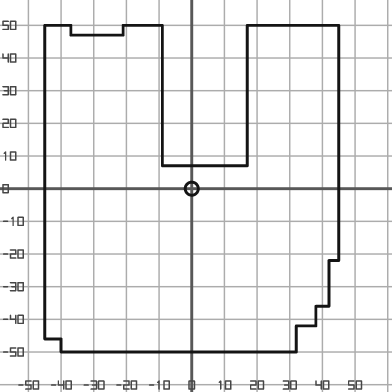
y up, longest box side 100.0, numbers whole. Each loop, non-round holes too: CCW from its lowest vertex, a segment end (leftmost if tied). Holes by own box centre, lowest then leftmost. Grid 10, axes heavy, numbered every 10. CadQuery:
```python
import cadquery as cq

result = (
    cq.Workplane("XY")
    .moveTo(-40.0, -50.0)
    .lineTo(32.0, -50.0)
    .lineTo(32.0, -42.0)
    .lineTo(38.0, -42.0)
    .lineTo(38.0, -36.0)
    .lineTo(42.0, -36.0)
    .lineTo(42.0, -22.0)
    .lineTo(45.0, -22.0)
    .lineTo(45.0, 50.0)
    .lineTo(17.0, 50.0)
    .lineTo(17.0, 7.0)
    .lineTo(-9.0, 7.0)
    .lineTo(-9.0, 50.0)
    .lineTo(-21.0, 50.0)
    .lineTo(-21.0, 47.0)
    .lineTo(-37.0, 47.0)
    .lineTo(-37.0, 50.0)
    .lineTo(-45.0, 50.0)
    .lineTo(-45.0, -46.0)
    .lineTo(-40.0, -46.0)
    .close()
    .moveTo(0.0, 0.0)
    .circle(2.0)
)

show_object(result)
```